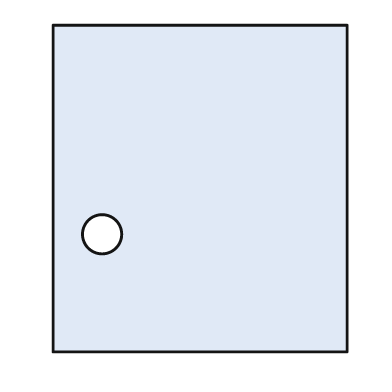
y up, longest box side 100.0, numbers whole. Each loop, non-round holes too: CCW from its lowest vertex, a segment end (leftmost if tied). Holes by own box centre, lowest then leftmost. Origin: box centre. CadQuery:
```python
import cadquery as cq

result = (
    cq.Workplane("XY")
    .moveTo(-45.0, -50.0)
    .lineTo(45.0, -50.0)
    .lineTo(45.0, 50.0)
    .lineTo(-45.0, 50.0)
    .close()
    .moveTo(-30.0, -14.0)
    .circle(6.0)
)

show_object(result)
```